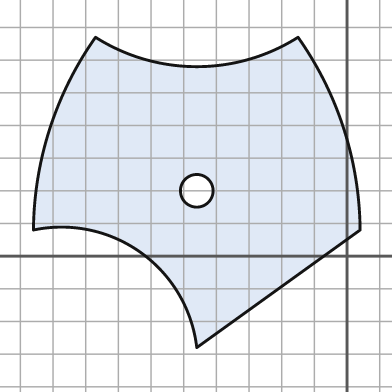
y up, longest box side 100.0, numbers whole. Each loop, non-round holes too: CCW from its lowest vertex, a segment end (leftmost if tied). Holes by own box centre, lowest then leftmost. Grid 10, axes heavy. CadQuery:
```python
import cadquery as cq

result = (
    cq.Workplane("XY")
    .moveTo(-46.0, -28.0)
    .lineTo(4.0, 8.0)
    .threePointArc((-1.0, 39.0), (-15.0, 67.0))
    .threePointArc((-46.0, 58.0), (-77.0, 67.0))
    .threePointArc((-91.0, 39.0), (-96.0, 8.0))
    .threePointArc((-63.0, 1.0), (-46.0, -28.0))
    .close()
    .moveTo(-46.0, 20.0)
    .circle(5.0)
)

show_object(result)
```